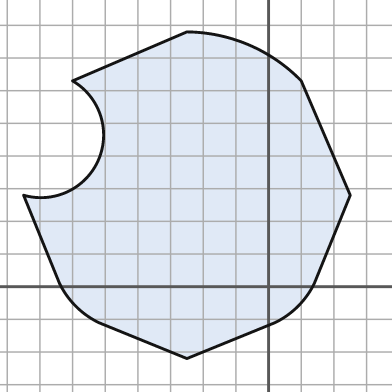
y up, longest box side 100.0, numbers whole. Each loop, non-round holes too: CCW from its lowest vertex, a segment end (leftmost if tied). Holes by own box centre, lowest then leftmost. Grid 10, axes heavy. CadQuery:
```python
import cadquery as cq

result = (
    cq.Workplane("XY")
    .moveTo(-25.0, -22.0)
    .lineTo(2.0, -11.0)
    .threePointArc((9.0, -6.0), (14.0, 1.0))
    .lineTo(25.0, 28.0)
    .lineTo(10.0, 63.0)
    .threePointArc((-6.0, 74.0), (-25.0, 78.0))
    .lineTo(-60.0, 63.0)
    .threePointArc((-52.0, 39.0), (-75.0, 28.0))
    .lineTo(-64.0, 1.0)
    .threePointArc((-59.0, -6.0), (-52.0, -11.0))
    .close()
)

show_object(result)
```